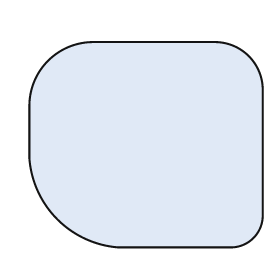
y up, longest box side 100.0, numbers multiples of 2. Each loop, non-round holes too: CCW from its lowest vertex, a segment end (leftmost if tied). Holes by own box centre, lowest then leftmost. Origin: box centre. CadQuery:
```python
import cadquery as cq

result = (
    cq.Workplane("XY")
    .moveTo(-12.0, -44.0)
    .lineTo(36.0, -44.0)
    .threePointArc((46.0, -40.0), (50.0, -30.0))
    .lineTo(50.0, 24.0)
    .threePointArc((44.0, 38.0), (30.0, 44.0))
    .lineTo(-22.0, 44.0)
    .threePointArc((-42.0, 36.0), (-50.0, 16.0))
    .lineTo(-50.0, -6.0)
    .threePointArc((-38.0, -32.0), (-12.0, -44.0))
    .close()
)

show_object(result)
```